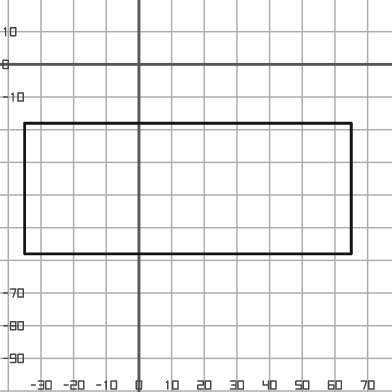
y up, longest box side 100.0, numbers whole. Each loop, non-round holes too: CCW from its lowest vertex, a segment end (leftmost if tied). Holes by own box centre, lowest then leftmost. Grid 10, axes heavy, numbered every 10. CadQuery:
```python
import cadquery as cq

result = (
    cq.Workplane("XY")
    .moveTo(-35.0, -58.0)
    .lineTo(65.0, -58.0)
    .lineTo(65.0, -18.0)
    .lineTo(-35.0, -18.0)
    .close()
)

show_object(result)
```